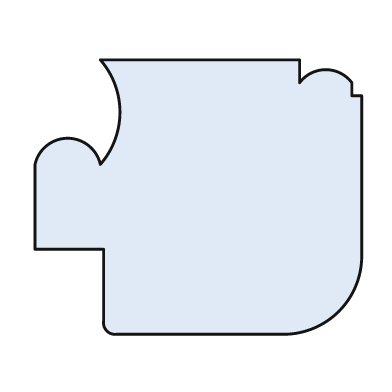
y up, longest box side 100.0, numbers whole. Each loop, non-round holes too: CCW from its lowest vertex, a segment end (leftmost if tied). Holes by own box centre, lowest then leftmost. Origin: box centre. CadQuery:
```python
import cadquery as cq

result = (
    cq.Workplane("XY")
    .moveTo(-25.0, -42.0)
    .lineTo(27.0, -42.0)
    .threePointArc((43.0, -35.0), (50.0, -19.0))
    .lineTo(50.0, 31.0)
    .lineTo(47.0, 31.0)
    .lineTo(47.0, 35.0)
    .threePointArc((39.0, 39.0), (31.0, 35.0))
    .lineTo(31.0, 42.0)
    .lineTo(-30.0, 42.0)
    .threePointArc((-24.0, 26.0), (-30.0, 10.0))
    .threePointArc((-40.0, 18.0), (-50.0, 10.0))
    .lineTo(-50.0, -16.0)
    .lineTo(-29.0, -16.0)
    .lineTo(-29.0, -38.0)
    .threePointArc((-28.0, -41.0), (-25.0, -42.0))
    .close()
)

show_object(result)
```